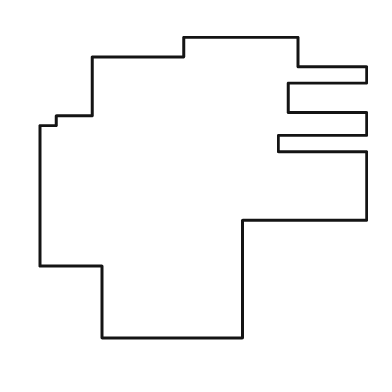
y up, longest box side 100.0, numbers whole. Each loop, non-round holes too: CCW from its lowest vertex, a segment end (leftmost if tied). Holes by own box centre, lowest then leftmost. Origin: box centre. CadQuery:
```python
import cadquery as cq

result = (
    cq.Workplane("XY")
    .moveTo(-31.0, -46.0)
    .lineTo(12.0, -46.0)
    .lineTo(12.0, -10.0)
    .lineTo(50.0, -10.0)
    .lineTo(50.0, 11.0)
    .lineTo(23.0, 11.0)
    .lineTo(23.0, 16.0)
    .lineTo(50.0, 16.0)
    .lineTo(50.0, 23.0)
    .lineTo(26.0, 23.0)
    .lineTo(26.0, 32.0)
    .lineTo(50.0, 32.0)
    .lineTo(50.0, 37.0)
    .lineTo(29.0, 37.0)
    .lineTo(29.0, 46.0)
    .lineTo(-6.0, 46.0)
    .lineTo(-6.0, 40.0)
    .lineTo(-34.0, 40.0)
    .lineTo(-34.0, 22.0)
    .lineTo(-45.0, 22.0)
    .lineTo(-45.0, 19.0)
    .lineTo(-50.0, 19.0)
    .lineTo(-50.0, -24.0)
    .lineTo(-31.0, -24.0)
    .close()
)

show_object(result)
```